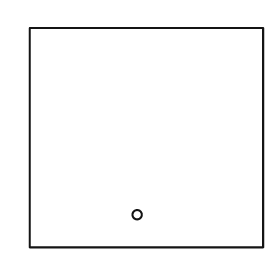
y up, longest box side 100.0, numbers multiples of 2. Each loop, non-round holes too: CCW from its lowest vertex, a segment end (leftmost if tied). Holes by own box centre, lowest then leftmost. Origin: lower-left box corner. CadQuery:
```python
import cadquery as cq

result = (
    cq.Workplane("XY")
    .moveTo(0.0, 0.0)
    .lineTo(100.0, 0.0)
    .lineTo(100.0, 94.0)
    .lineTo(0.0, 94.0)
    .close()
    .moveTo(46.0, 14.0)
    .circle(2.0)
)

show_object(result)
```